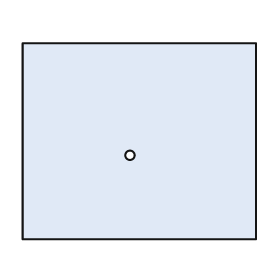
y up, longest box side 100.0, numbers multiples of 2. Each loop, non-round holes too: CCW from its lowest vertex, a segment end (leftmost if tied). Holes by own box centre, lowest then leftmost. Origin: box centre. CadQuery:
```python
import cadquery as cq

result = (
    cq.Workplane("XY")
    .moveTo(-50.0, -42.0)
    .lineTo(50.0, -42.0)
    .lineTo(50.0, 42.0)
    .lineTo(-50.0, 42.0)
    .close()
    .moveTo(-4.0, -6.0)
    .circle(2.0)
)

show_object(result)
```